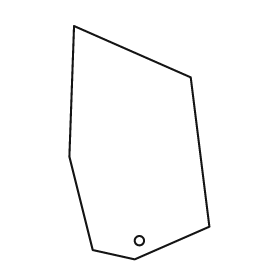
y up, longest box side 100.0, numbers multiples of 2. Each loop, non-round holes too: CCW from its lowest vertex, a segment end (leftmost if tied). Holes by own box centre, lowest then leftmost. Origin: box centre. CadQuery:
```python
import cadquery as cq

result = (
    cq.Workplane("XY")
    .moveTo(-2.0, -50.0)
    .lineTo(30.0, -36.0)
    .lineTo(22.0, 28.0)
    .lineTo(-28.0, 50.0)
    .lineTo(-30.0, -6.0)
    .lineTo(-20.0, -46.0)
    .close()
    .moveTo(0.0, -42.0)
    .circle(2.0)
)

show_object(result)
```